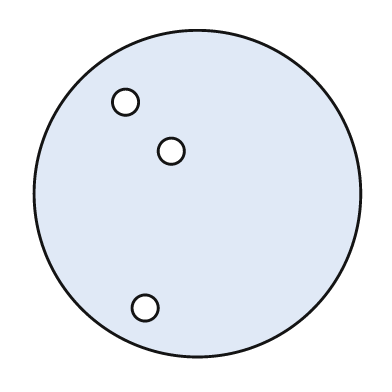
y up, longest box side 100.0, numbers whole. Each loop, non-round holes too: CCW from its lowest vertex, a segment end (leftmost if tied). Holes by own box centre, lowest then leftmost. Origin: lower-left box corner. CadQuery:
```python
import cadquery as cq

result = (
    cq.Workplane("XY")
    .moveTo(50.0, 50.0)
    .circle(50.0)
    .moveTo(34.0, 15.0)
    .circle(4.0)
    .moveTo(42.0, 63.0)
    .circle(4.0)
    .moveTo(28.0, 78.0)
    .circle(4.0)
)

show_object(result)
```